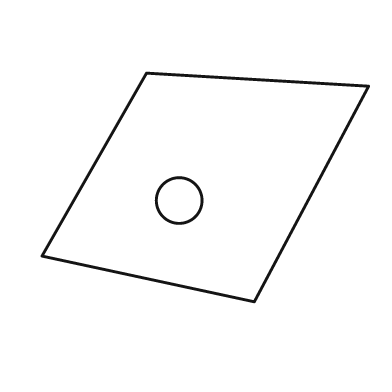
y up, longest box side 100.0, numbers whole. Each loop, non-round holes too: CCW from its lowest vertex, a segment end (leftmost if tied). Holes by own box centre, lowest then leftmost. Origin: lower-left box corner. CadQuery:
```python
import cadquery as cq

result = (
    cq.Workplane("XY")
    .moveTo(65.0, 0.0)
    .lineTo(100.0, 66.0)
    .lineTo(32.0, 70.0)
    .lineTo(0.0, 14.0)
    .close()
    .moveTo(42.0, 31.0)
    .circle(7.0)
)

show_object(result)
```